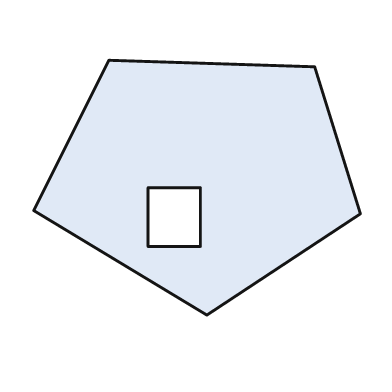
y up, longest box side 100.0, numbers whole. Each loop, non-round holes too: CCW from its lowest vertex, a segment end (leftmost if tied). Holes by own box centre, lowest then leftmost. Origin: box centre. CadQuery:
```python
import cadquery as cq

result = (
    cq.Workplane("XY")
    .moveTo(3.0, -39.0)
    .lineTo(50.0, -8.0)
    .lineTo(36.0, 37.0)
    .lineTo(-27.0, 39.0)
    .lineTo(-50.0, -7.0)
    .close()
    .moveTo(-15.0, -18.0)
    .lineTo(1.0, -18.0)
    .lineTo(1.0, 0.0)
    .lineTo(-15.0, 0.0)
    .close()
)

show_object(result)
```